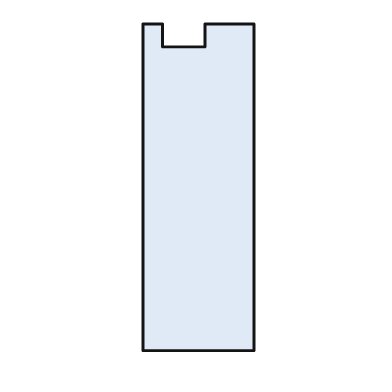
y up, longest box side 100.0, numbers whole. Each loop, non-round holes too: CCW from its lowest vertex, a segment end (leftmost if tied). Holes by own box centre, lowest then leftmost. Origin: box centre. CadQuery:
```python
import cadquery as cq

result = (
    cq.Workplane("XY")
    .moveTo(-17.0, -50.0)
    .lineTo(17.0, -50.0)
    .lineTo(17.0, 50.0)
    .lineTo(2.0, 50.0)
    .lineTo(2.0, 43.0)
    .lineTo(-11.0, 43.0)
    .lineTo(-11.0, 50.0)
    .lineTo(-17.0, 50.0)
    .close()
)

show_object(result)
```